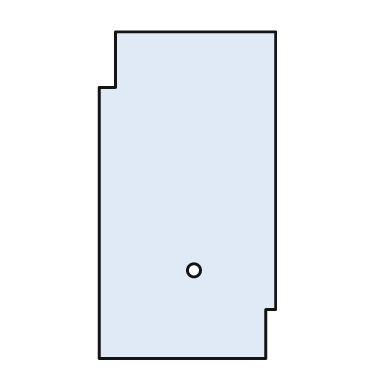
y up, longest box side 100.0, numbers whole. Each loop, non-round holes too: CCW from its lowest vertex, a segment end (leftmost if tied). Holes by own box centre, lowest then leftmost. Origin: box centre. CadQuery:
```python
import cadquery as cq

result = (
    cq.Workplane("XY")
    .moveTo(-27.0, -50.0)
    .lineTo(24.0, -50.0)
    .lineTo(24.0, -35.0)
    .lineTo(27.0, -35.0)
    .lineTo(27.0, 50.0)
    .lineTo(-22.0, 50.0)
    .lineTo(-22.0, 33.0)
    .lineTo(-27.0, 33.0)
    .close()
    .moveTo(2.0, -23.0)
    .circle(2.0)
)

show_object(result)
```